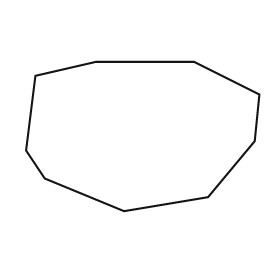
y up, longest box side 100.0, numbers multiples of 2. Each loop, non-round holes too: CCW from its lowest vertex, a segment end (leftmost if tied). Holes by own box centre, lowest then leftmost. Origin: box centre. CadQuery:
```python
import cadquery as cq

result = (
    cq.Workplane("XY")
    .moveTo(-8.0, -32.0)
    .lineTo(28.0, -26.0)
    .lineTo(48.0, -2.0)
    .lineTo(50.0, 18.0)
    .lineTo(22.0, 32.0)
    .lineTo(-20.0, 32.0)
    .lineTo(-46.0, 26.0)
    .lineTo(-50.0, -6.0)
    .lineTo(-42.0, -18.0)
    .close()
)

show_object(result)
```